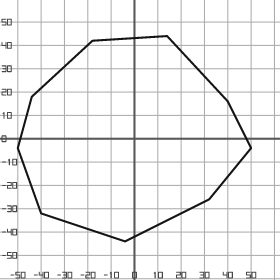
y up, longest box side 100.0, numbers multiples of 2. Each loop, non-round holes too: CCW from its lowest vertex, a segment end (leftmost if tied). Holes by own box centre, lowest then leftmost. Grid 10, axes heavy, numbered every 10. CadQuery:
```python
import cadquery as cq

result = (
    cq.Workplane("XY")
    .moveTo(-4.0, -44.0)
    .lineTo(32.0, -26.0)
    .lineTo(50.0, -4.0)
    .lineTo(40.0, 16.0)
    .lineTo(14.0, 44.0)
    .lineTo(-18.0, 42.0)
    .lineTo(-44.0, 18.0)
    .lineTo(-50.0, -4.0)
    .lineTo(-40.0, -32.0)
    .close()
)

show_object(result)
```